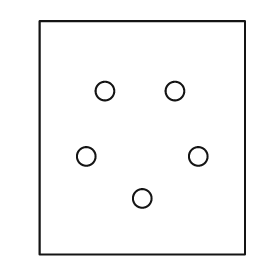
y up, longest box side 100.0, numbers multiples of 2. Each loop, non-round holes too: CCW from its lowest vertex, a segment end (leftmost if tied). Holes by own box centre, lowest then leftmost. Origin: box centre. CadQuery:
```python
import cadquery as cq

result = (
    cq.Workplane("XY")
    .moveTo(-44.0, -50.0)
    .lineTo(44.0, -50.0)
    .lineTo(44.0, 50.0)
    .lineTo(-44.0, 50.0)
    .close()
    .moveTo(0.0, -26.0)
    .circle(4.0)
    .moveTo(-24.0, -8.0)
    .circle(4.0)
    .moveTo(24.0, -8.0)
    .circle(4.0)
    .moveTo(-16.0, 20.0)
    .circle(4.0)
    .moveTo(14.0, 20.0)
    .circle(4.0)
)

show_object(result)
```